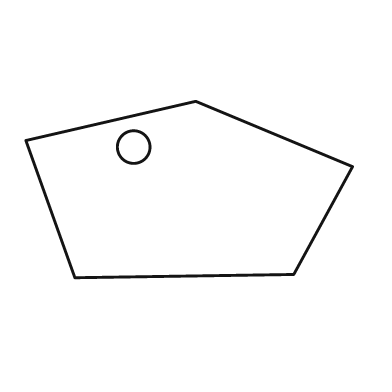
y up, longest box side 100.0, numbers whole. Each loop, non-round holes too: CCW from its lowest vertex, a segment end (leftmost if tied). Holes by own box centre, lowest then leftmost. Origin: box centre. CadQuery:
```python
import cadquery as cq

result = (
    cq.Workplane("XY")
    .moveTo(-35.0, -27.0)
    .lineTo(32.0, -26.0)
    .lineTo(50.0, 7.0)
    .lineTo(2.0, 27.0)
    .lineTo(-50.0, 15.0)
    .close()
    .moveTo(-17.0, 13.0)
    .circle(5.0)
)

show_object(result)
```